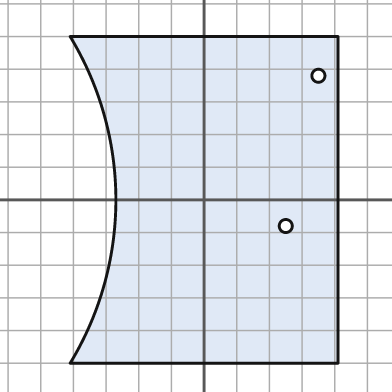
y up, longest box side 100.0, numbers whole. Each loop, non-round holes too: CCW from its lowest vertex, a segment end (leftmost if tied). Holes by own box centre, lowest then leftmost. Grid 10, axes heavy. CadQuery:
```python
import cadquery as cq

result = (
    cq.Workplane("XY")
    .moveTo(-41.0, -50.0)
    .lineTo(41.0, -50.0)
    .lineTo(41.0, 50.0)
    .lineTo(-41.0, 50.0)
    .threePointArc((-27.0, 0.0), (-41.0, -50.0))
    .close()
    .moveTo(25.0, -8.0)
    .circle(2.0)
    .moveTo(35.0, 38.0)
    .circle(2.0)
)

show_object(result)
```